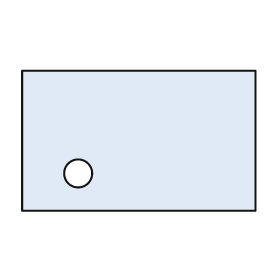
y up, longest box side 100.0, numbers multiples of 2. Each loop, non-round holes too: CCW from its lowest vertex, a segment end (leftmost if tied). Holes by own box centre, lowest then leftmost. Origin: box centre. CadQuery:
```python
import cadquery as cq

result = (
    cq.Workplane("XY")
    .moveTo(-50.0, -30.0)
    .lineTo(50.0, -30.0)
    .lineTo(50.0, 30.0)
    .lineTo(-50.0, 30.0)
    .close()
    .moveTo(-26.0, -14.0)
    .circle(6.0)
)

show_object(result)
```